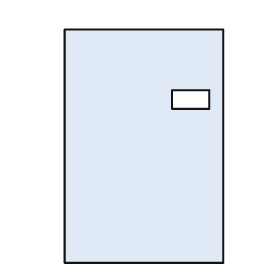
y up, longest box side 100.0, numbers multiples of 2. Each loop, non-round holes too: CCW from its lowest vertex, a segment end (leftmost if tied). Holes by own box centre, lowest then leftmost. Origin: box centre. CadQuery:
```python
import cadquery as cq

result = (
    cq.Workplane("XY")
    .moveTo(-34.0, -50.0)
    .lineTo(34.0, -50.0)
    .lineTo(34.0, 50.0)
    .lineTo(-34.0, 50.0)
    .close()
    .moveTo(12.0, 16.0)
    .lineTo(28.0, 16.0)
    .lineTo(28.0, 24.0)
    .lineTo(12.0, 24.0)
    .close()
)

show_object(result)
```